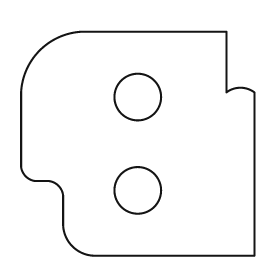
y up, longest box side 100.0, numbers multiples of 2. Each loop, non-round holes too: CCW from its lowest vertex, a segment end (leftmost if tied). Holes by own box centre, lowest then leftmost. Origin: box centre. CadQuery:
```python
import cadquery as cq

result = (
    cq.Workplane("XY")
    .moveTo(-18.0, -48.0)
    .lineTo(50.0, -48.0)
    .lineTo(50.0, 22.0)
    .threePointArc((44.0, 24.0), (38.0, 22.0))
    .lineTo(38.0, 48.0)
    .lineTo(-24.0, 48.0)
    .threePointArc((-42.0, 40.0), (-50.0, 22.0))
    .lineTo(-50.0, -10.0)
    .threePointArc((-48.0, -14.0), (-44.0, -16.0))
    .lineTo(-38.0, -16.0)
    .threePointArc((-34.0, -18.0), (-32.0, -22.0))
    .lineTo(-32.0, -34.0)
    .threePointArc((-28.0, -44.0), (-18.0, -48.0))
    .close()
    .moveTo(0.0, -20.0)
    .circle(10.0)
    .moveTo(0.0, 20.0)
    .circle(10.0)
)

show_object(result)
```